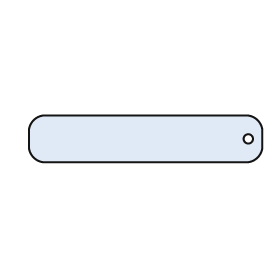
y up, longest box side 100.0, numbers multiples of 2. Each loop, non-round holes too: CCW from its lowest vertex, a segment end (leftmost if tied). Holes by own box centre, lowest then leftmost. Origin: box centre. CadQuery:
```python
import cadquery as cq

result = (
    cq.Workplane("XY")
    .moveTo(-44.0, -10.0)
    .lineTo(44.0, -10.0)
    .threePointArc((48.0, -8.0), (50.0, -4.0))
    .lineTo(50.0, 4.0)
    .threePointArc((48.0, 8.0), (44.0, 10.0))
    .lineTo(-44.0, 10.0)
    .threePointArc((-48.0, 8.0), (-50.0, 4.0))
    .lineTo(-50.0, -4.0)
    .threePointArc((-48.0, -8.0), (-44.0, -10.0))
    .close()
    .moveTo(44.0, 0.0)
    .circle(2.0)
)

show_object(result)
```